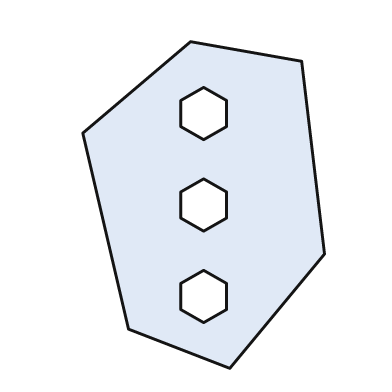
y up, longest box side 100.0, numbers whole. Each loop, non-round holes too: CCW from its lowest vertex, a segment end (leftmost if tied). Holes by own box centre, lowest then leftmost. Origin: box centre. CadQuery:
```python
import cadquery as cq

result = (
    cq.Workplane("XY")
    .moveTo(8.0, -50.0)
    .lineTo(37.0, -15.0)
    .lineTo(30.0, 44.0)
    .lineTo(-4.0, 50.0)
    .lineTo(-37.0, 22.0)
    .lineTo(-23.0, -38.0)
    .close()
    .moveTo(0.0, -36.0)
    .lineTo(7.0, -32.0)
    .lineTo(7.0, -24.0)
    .lineTo(0.0, -20.0)
    .lineTo(-7.0, -24.0)
    .lineTo(-7.0, -32.0)
    .close()
    .moveTo(0.0, -8.0)
    .lineTo(7.0, -4.0)
    .lineTo(7.0, 4.0)
    .lineTo(0.0, 8.0)
    .lineTo(-7.0, 4.0)
    .lineTo(-7.0, -4.0)
    .close()
    .moveTo(0.0, 20.0)
    .lineTo(7.0, 24.0)
    .lineTo(7.0, 32.0)
    .lineTo(0.0, 36.0)
    .lineTo(-7.0, 32.0)
    .lineTo(-7.0, 24.0)
    .close()
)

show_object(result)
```